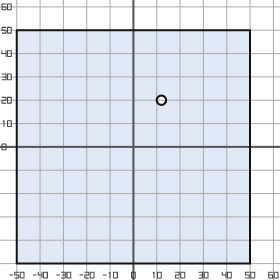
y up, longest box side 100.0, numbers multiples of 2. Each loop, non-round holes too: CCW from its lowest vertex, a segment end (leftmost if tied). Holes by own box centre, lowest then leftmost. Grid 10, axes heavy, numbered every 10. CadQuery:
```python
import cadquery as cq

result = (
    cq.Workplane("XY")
    .moveTo(-50.0, -50.0)
    .lineTo(50.0, -50.0)
    .lineTo(50.0, 50.0)
    .lineTo(-50.0, 50.0)
    .close()
    .moveTo(12.0, 20.0)
    .circle(2.0)
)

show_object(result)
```